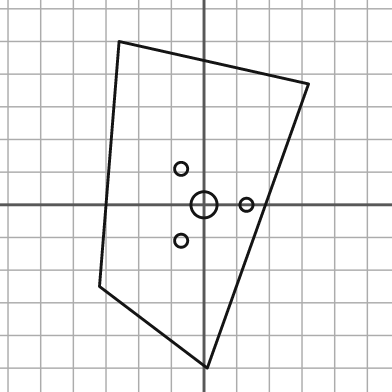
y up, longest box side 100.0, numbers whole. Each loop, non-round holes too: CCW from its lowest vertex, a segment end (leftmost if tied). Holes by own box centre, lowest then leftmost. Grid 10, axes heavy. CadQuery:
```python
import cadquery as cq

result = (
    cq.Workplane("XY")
    .moveTo(1.0, -50.0)
    .lineTo(32.0, 37.0)
    .lineTo(-26.0, 50.0)
    .lineTo(-32.0, -25.0)
    .close()
    .moveTo(-7.0, -11.0)
    .circle(2.0)
    .moveTo(0.0, 0.0)
    .circle(4.0)
    .moveTo(13.0, 0.0)
    .circle(2.0)
    .moveTo(-7.0, 11.0)
    .circle(2.0)
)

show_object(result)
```